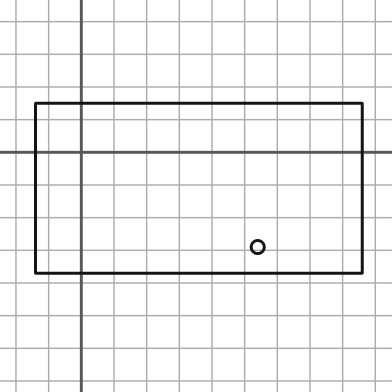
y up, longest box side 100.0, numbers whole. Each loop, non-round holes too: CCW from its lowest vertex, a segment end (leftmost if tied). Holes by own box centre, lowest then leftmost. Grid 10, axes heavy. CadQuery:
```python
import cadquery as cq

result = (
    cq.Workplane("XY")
    .moveTo(-14.0, -37.0)
    .lineTo(86.0, -37.0)
    .lineTo(86.0, 15.0)
    .lineTo(-14.0, 15.0)
    .close()
    .moveTo(54.0, -29.0)
    .circle(2.0)
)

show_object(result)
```